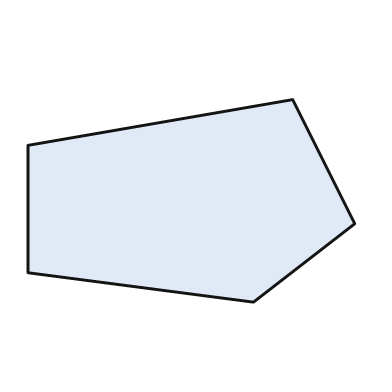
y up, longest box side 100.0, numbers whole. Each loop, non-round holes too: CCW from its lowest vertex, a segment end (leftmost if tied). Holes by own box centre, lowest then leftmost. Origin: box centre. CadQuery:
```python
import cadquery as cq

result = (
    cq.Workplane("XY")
    .moveTo(19.0, -31.0)
    .lineTo(50.0, -7.0)
    .lineTo(31.0, 31.0)
    .lineTo(-50.0, 17.0)
    .lineTo(-50.0, -22.0)
    .close()
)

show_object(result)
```